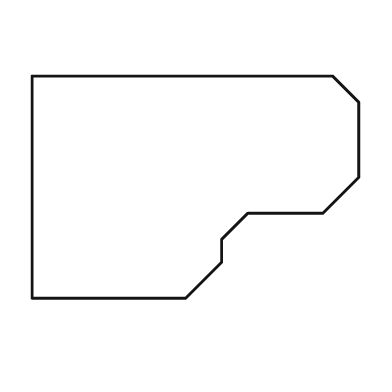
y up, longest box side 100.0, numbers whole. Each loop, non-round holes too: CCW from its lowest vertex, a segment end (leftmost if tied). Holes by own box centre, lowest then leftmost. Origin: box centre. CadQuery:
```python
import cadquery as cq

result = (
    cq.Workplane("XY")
    .moveTo(-50.0, -34.0)
    .lineTo(-3.0, -34.0)
    .lineTo(8.0, -23.0)
    .lineTo(8.0, -16.0)
    .lineTo(16.0, -8.0)
    .lineTo(39.0, -8.0)
    .lineTo(50.0, 3.0)
    .lineTo(50.0, 26.0)
    .lineTo(42.0, 34.0)
    .lineTo(-50.0, 34.0)
    .close()
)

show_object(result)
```